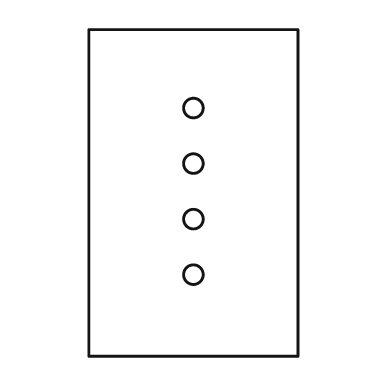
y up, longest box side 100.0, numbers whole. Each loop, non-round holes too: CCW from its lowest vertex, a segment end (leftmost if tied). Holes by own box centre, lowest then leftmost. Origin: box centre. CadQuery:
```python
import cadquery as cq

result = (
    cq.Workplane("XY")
    .moveTo(-32.0, -50.0)
    .lineTo(32.0, -50.0)
    .lineTo(32.0, 50.0)
    .lineTo(-32.0, 50.0)
    .close()
    .moveTo(0.0, -25.0)
    .circle(3.0)
    .moveTo(0.0, -8.0)
    .circle(3.0)
    .moveTo(0.0, 9.0)
    .circle(3.0)
    .moveTo(0.0, 26.0)
    .circle(3.0)
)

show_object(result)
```